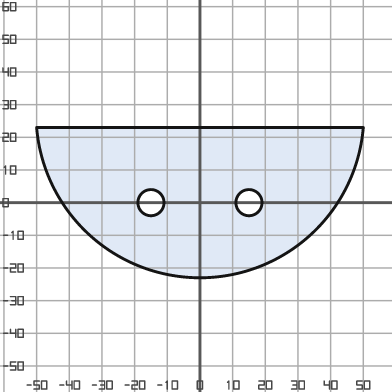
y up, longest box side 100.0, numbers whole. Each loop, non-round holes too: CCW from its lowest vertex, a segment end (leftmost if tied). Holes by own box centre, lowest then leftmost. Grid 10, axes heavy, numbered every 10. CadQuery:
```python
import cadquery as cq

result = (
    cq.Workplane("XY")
    .moveTo(-50.0, 23.0)
    .threePointArc((0.0, -23.0), (50.0, 23.0))
    .close()
    .moveTo(-15.0, 0.0)
    .circle(4.0)
    .moveTo(15.0, 0.0)
    .circle(4.0)
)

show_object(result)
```